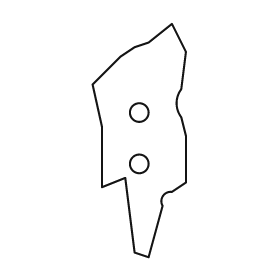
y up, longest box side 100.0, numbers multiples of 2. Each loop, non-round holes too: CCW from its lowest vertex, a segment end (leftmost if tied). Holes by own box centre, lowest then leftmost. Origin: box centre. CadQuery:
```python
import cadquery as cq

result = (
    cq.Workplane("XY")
    .moveTo(4.0, -50.0)
    .lineTo(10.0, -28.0)
    .threePointArc((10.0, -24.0), (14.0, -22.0))
    .lineTo(20.0, -18.0)
    .lineTo(20.0, 2.0)
    .lineTo(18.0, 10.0)
    .threePointArc((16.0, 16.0), (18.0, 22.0))
    .lineTo(20.0, 38.0)
    .lineTo(14.0, 50.0)
    .lineTo(4.0, 42.0)
    .lineTo(-2.0, 40.0)
    .lineTo(-8.0, 36.0)
    .lineTo(-20.0, 24.0)
    .lineTo(-16.0, 6.0)
    .lineTo(-16.0, -20.0)
    .lineTo(-6.0, -16.0)
    .lineTo(-2.0, -48.0)
    .close()
    .moveTo(0.0, -10.0)
    .circle(4.0)
    .moveTo(0.0, 12.0)
    .circle(4.0)
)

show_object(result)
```